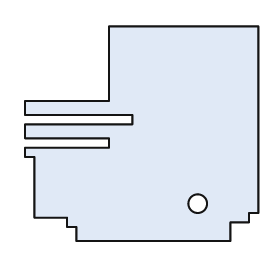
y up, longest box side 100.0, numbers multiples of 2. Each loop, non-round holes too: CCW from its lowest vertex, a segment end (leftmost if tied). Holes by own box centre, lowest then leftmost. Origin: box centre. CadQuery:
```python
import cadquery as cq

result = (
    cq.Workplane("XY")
    .moveTo(-28.0, -46.0)
    .lineTo(38.0, -46.0)
    .lineTo(38.0, -38.0)
    .lineTo(46.0, -38.0)
    .lineTo(46.0, -34.0)
    .lineTo(50.0, -34.0)
    .lineTo(50.0, 46.0)
    .lineTo(-14.0, 46.0)
    .lineTo(-14.0, 14.0)
    .lineTo(-50.0, 14.0)
    .lineTo(-50.0, 8.0)
    .lineTo(-4.0, 8.0)
    .lineTo(-4.0, 4.0)
    .lineTo(-50.0, 4.0)
    .lineTo(-50.0, -2.0)
    .lineTo(-14.0, -2.0)
    .lineTo(-14.0, -6.0)
    .lineTo(-50.0, -6.0)
    .lineTo(-50.0, -10.0)
    .lineTo(-46.0, -10.0)
    .lineTo(-46.0, -36.0)
    .lineTo(-32.0, -36.0)
    .lineTo(-32.0, -40.0)
    .lineTo(-28.0, -40.0)
    .close()
    .moveTo(24.0, -30.0)
    .circle(4.0)
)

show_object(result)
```